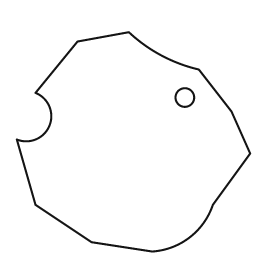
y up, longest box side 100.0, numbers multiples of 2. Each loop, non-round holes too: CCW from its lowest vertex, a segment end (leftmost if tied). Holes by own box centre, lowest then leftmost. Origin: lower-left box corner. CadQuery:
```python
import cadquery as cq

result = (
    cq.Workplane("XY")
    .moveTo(58.0, 0.0)
    .threePointArc((74.0, 6.0), (84.0, 20.0))
    .lineTo(100.0, 42.0)
    .lineTo(92.0, 60.0)
    .lineTo(78.0, 78.0)
    .threePointArc((62.0, 84.0), (48.0, 94.0))
    .lineTo(26.0, 90.0)
    .lineTo(8.0, 68.0)
    .threePointArc((14.0, 54.0), (0.0, 48.0))
    .lineTo(8.0, 20.0)
    .lineTo(32.0, 4.0)
    .close()
    .moveTo(72.0, 66.0)
    .circle(4.0)
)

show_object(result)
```